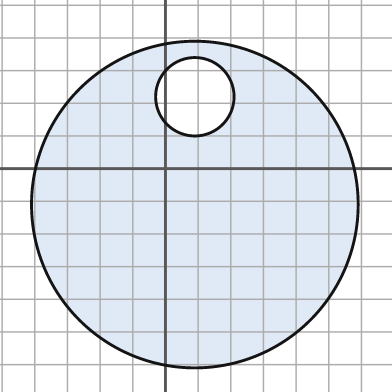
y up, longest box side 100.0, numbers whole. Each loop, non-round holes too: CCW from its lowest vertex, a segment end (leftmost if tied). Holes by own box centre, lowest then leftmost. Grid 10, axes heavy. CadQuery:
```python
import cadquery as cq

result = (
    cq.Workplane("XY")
    .moveTo(9.0, -11.0)
    .circle(50.0)
    .moveTo(9.0, 22.0)
    .circle(12.0)
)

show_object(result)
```